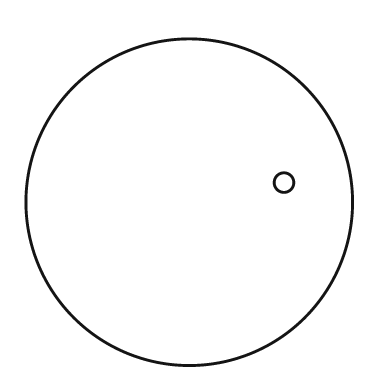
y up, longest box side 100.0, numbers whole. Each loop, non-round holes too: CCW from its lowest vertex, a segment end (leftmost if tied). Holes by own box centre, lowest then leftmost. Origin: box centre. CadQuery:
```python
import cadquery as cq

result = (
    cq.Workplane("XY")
    .moveTo(0.0, 0.0)
    .circle(50.0)
    .moveTo(29.0, 6.0)
    .circle(3.0)
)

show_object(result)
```